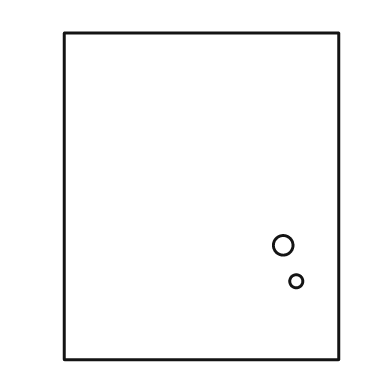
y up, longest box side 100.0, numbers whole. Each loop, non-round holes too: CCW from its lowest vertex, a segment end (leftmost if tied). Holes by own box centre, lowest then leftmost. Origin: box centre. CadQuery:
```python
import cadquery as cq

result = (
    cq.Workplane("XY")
    .moveTo(-42.0, -50.0)
    .lineTo(42.0, -50.0)
    .lineTo(42.0, 50.0)
    .lineTo(-42.0, 50.0)
    .close()
    .moveTo(29.0, -26.0)
    .circle(2.0)
    .moveTo(25.0, -15.0)
    .circle(3.0)
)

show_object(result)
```